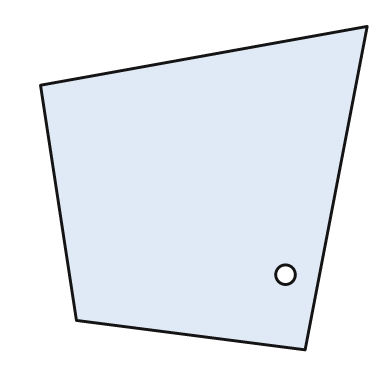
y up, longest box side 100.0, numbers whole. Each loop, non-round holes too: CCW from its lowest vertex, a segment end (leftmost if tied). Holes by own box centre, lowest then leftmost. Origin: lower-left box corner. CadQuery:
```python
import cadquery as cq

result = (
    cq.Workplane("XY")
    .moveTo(81.0, 0.0)
    .lineTo(100.0, 99.0)
    .lineTo(0.0, 81.0)
    .lineTo(11.0, 9.0)
    .close()
    .moveTo(75.0, 23.0)
    .circle(3.0)
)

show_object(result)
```